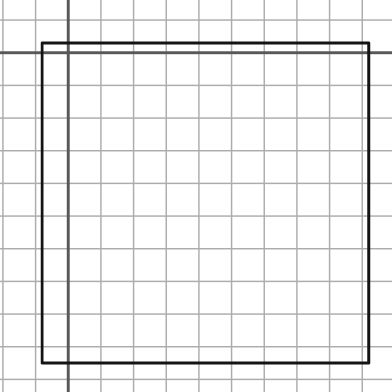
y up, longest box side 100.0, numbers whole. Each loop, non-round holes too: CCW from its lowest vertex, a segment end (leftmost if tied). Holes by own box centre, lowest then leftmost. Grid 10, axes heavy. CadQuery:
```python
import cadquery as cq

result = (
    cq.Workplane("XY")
    .moveTo(-8.0, -95.0)
    .lineTo(92.0, -95.0)
    .lineTo(92.0, 3.0)
    .lineTo(-8.0, 3.0)
    .close()
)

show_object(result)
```